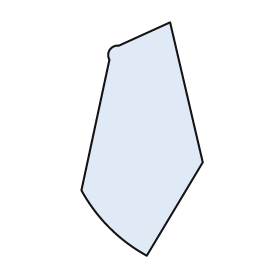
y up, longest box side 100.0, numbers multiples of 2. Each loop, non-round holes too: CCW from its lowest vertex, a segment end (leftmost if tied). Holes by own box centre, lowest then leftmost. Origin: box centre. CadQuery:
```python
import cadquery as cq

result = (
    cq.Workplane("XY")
    .moveTo(2.0, -50.0)
    .lineTo(26.0, -10.0)
    .lineTo(12.0, 50.0)
    .lineTo(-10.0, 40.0)
    .threePointArc((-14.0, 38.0), (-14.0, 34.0))
    .lineTo(-26.0, -22.0)
    .threePointArc((-14.0, -38.0), (2.0, -50.0))
    .close()
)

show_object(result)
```